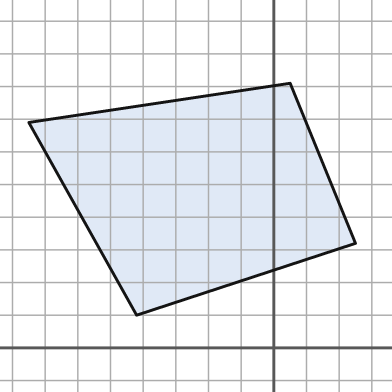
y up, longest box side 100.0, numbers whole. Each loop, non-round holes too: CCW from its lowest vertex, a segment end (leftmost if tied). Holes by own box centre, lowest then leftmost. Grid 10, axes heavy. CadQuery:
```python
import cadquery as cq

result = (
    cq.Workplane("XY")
    .moveTo(-42.0, 10.0)
    .lineTo(25.0, 32.0)
    .lineTo(5.0, 81.0)
    .lineTo(-75.0, 69.0)
    .close()
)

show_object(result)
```